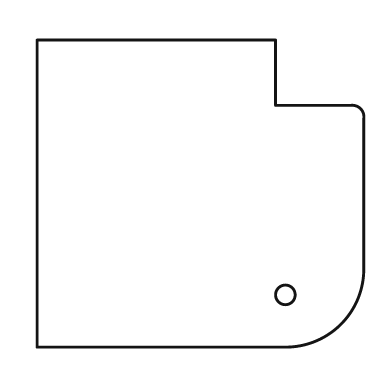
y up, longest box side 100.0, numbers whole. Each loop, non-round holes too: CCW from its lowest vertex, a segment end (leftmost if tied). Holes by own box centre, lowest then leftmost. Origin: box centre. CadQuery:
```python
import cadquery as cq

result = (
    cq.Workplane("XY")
    .moveTo(-50.0, -47.0)
    .lineTo(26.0, -47.0)
    .threePointArc((43.0, -40.0), (50.0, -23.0))
    .lineTo(50.0, 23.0)
    .threePointArc((49.0, 26.0), (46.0, 27.0))
    .lineTo(23.0, 27.0)
    .lineTo(23.0, 47.0)
    .lineTo(-50.0, 47.0)
    .close()
    .moveTo(26.0, -31.0)
    .circle(3.0)
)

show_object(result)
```